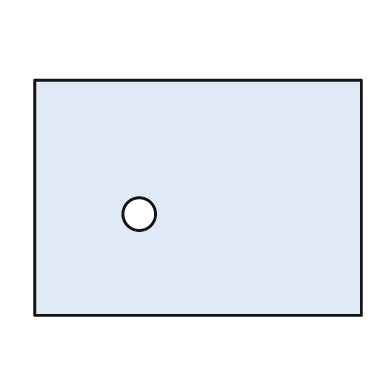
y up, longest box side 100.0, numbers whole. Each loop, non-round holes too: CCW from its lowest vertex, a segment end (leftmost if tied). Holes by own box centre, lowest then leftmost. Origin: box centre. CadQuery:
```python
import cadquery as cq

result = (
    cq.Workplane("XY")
    .moveTo(-50.0, -36.0)
    .lineTo(50.0, -36.0)
    .lineTo(50.0, 36.0)
    .lineTo(-50.0, 36.0)
    .close()
    .moveTo(-18.0, -5.0)
    .circle(5.0)
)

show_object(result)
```